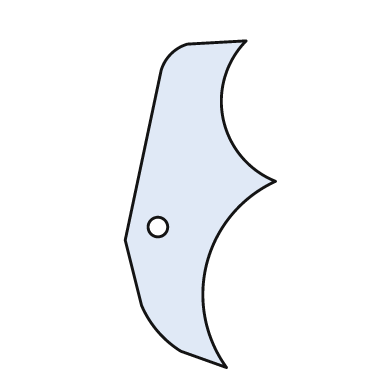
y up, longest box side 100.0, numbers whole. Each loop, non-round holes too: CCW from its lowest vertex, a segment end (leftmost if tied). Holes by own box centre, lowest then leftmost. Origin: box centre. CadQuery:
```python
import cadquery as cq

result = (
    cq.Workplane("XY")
    .moveTo(8.0, -50.0)
    .threePointArc((2.0, -18.0), (23.0, 7.0))
    .threePointArc((7.0, 26.0), (14.0, 50.0))
    .lineTo(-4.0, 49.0)
    .threePointArc((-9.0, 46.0), (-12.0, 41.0))
    .lineTo(-23.0, -11.0)
    .lineTo(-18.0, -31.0)
    .threePointArc((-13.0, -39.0), (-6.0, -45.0))
    .close()
    .moveTo(-13.0, -7.0)
    .circle(3.0)
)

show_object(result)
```